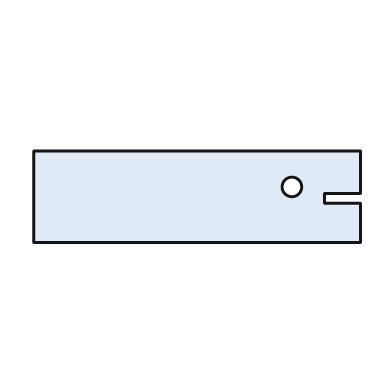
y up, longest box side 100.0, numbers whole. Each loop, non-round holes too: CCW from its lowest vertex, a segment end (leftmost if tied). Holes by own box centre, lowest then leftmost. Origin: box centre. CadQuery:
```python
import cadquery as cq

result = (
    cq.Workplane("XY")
    .moveTo(-50.0, -14.0)
    .lineTo(50.0, -14.0)
    .lineTo(50.0, -2.0)
    .lineTo(39.0, -2.0)
    .lineTo(39.0, 1.0)
    .lineTo(50.0, 1.0)
    .lineTo(50.0, 14.0)
    .lineTo(-50.0, 14.0)
    .close()
    .moveTo(29.0, 3.0)
    .circle(3.0)
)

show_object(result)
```